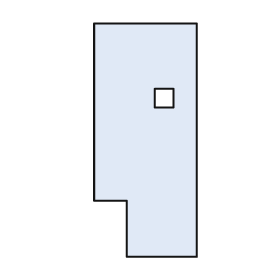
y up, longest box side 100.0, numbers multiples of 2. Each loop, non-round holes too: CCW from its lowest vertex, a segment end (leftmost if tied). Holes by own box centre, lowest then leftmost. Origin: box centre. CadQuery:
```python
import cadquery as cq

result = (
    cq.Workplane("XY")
    .moveTo(-8.0, -50.0)
    .lineTo(22.0, -50.0)
    .lineTo(22.0, 50.0)
    .lineTo(-22.0, 50.0)
    .lineTo(-22.0, -26.0)
    .lineTo(-8.0, -26.0)
    .close()
    .moveTo(4.0, 14.0)
    .lineTo(12.0, 14.0)
    .lineTo(12.0, 22.0)
    .lineTo(4.0, 22.0)
    .close()
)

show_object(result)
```